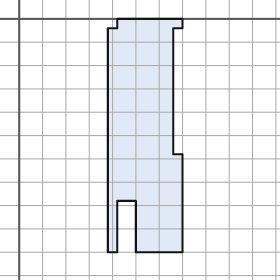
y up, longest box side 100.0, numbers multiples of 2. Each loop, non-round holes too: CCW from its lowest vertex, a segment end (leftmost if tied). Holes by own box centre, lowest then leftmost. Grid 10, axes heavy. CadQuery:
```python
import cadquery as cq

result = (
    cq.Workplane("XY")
    .moveTo(38.0, -100.0)
    .lineTo(42.0, -100.0)
    .lineTo(42.0, -78.0)
    .lineTo(50.0, -78.0)
    .lineTo(50.0, -100.0)
    .lineTo(70.0, -100.0)
    .lineTo(70.0, -58.0)
    .lineTo(66.0, -58.0)
    .lineTo(66.0, -4.0)
    .lineTo(70.0, -4.0)
    .lineTo(70.0, 0.0)
    .lineTo(42.0, 0.0)
    .lineTo(42.0, -4.0)
    .lineTo(38.0, -4.0)
    .close()
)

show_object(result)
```